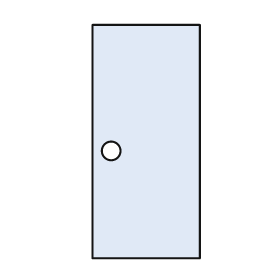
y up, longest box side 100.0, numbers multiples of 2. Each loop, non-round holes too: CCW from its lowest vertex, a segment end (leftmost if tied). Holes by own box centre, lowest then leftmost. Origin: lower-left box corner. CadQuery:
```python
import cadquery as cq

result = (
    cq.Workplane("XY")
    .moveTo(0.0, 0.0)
    .lineTo(46.0, 0.0)
    .lineTo(46.0, 100.0)
    .lineTo(0.0, 100.0)
    .close()
    .moveTo(8.0, 46.0)
    .circle(4.0)
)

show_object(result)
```